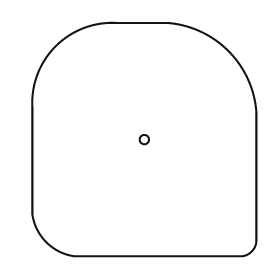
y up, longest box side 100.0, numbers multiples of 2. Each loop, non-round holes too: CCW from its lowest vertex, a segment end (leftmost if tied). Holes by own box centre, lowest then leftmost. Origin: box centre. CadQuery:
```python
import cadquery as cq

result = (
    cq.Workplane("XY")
    .moveTo(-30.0, -50.0)
    .lineTo(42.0, -50.0)
    .threePointArc((46.0, -48.0), (48.0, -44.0))
    .lineTo(48.0, 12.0)
    .threePointArc((36.0, 38.0), (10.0, 50.0))
    .lineTo(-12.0, 50.0)
    .threePointArc((-38.0, 40.0), (-48.0, 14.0))
    .lineTo(-48.0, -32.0)
    .threePointArc((-42.0, -44.0), (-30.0, -50.0))
    .close()
    .moveTo(0.0, 0.0)
    .circle(2.0)
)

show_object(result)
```